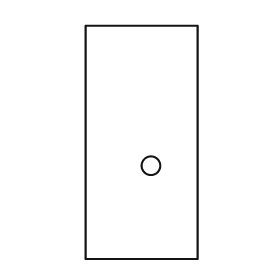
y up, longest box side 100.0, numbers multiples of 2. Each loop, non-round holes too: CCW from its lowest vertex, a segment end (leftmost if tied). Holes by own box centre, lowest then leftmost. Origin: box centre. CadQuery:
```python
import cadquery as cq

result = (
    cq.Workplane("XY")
    .moveTo(-24.0, -50.0)
    .lineTo(24.0, -50.0)
    .lineTo(24.0, 50.0)
    .lineTo(-24.0, 50.0)
    .close()
    .moveTo(4.0, -10.0)
    .circle(4.0)
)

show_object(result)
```